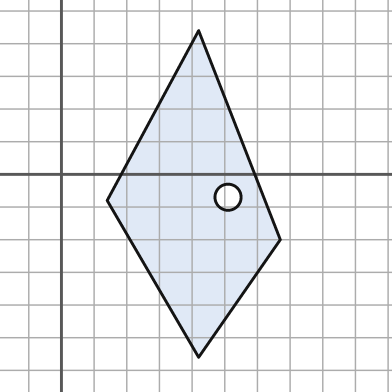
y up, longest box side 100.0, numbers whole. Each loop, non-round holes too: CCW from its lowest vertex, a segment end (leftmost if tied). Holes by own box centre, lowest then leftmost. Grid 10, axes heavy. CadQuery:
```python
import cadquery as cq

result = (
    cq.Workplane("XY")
    .moveTo(42.0, -56.0)
    .lineTo(67.0, -20.0)
    .lineTo(42.0, 44.0)
    .lineTo(14.0, -8.0)
    .close()
    .moveTo(51.0, -7.0)
    .circle(4.0)
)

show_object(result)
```